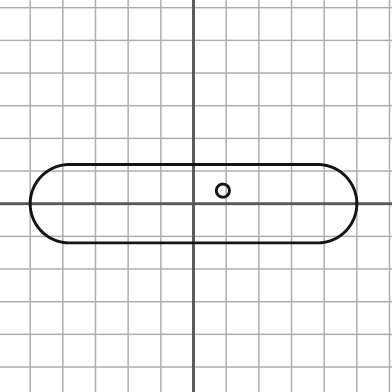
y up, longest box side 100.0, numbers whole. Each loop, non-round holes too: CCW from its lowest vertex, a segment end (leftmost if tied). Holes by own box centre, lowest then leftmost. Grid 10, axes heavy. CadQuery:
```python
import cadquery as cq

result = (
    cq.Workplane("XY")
    .moveTo(-38.0, -12.0)
    .lineTo(38.0, -12.0)
    .threePointArc((50.0, 0.0), (38.0, 12.0))
    .lineTo(-38.0, 12.0)
    .threePointArc((-50.0, 0.0), (-38.0, -12.0))
    .close()
    .moveTo(9.0, 4.0)
    .circle(2.0)
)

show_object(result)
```